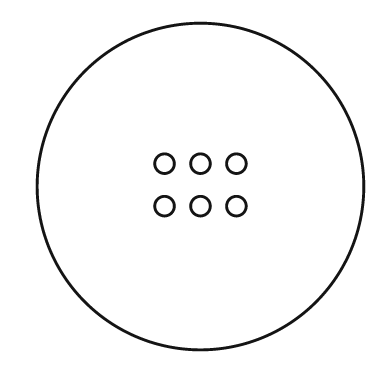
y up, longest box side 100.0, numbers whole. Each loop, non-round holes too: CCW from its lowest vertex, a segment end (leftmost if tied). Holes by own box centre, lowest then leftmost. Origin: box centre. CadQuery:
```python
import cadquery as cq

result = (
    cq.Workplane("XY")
    .moveTo(0.0, 0.0)
    .circle(50.0)
    .moveTo(-11.0, -6.0)
    .circle(3.0)
    .moveTo(0.0, -6.0)
    .circle(3.0)
    .moveTo(11.0, -6.0)
    .circle(3.0)
    .moveTo(-11.0, 7.0)
    .circle(3.0)
    .moveTo(0.0, 7.0)
    .circle(3.0)
    .moveTo(11.0, 7.0)
    .circle(3.0)
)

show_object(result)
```